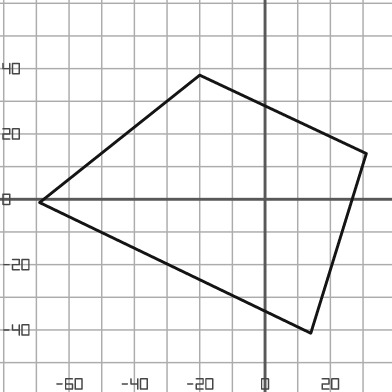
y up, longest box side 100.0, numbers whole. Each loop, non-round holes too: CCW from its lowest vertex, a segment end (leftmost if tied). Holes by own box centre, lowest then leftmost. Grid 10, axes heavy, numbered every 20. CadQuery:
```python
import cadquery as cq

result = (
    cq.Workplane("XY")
    .moveTo(14.0, -41.0)
    .lineTo(31.0, 14.0)
    .lineTo(-20.0, 38.0)
    .lineTo(-69.0, -1.0)
    .close()
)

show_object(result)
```